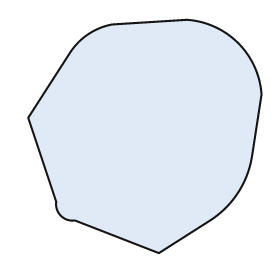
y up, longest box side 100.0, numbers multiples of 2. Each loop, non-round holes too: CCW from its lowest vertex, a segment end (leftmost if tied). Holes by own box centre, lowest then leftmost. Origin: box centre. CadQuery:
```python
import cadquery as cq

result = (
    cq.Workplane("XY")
    .moveTo(6.0, -50.0)
    .lineTo(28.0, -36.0)
    .threePointArc((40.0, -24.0), (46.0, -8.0))
    .lineTo(50.0, 18.0)
    .threePointArc((40.0, 40.0), (18.0, 50.0))
    .lineTo(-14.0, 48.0)
    .threePointArc((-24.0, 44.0), (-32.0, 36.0))
    .lineTo(-50.0, 8.0)
    .lineTo(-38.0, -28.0)
    .threePointArc((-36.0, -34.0), (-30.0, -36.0))
    .close()
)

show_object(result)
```